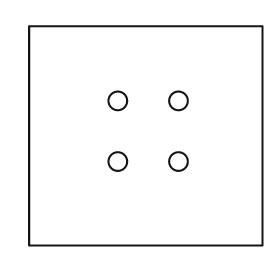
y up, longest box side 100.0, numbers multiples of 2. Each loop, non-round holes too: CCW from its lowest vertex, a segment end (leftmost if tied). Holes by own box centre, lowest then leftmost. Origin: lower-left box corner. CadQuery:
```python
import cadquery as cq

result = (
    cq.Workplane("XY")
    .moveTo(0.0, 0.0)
    .lineTo(100.0, 0.0)
    .lineTo(100.0, 94.0)
    .lineTo(0.0, 94.0)
    .close()
    .moveTo(38.0, 36.0)
    .circle(4.0)
    .moveTo(64.0, 36.0)
    .circle(4.0)
    .moveTo(38.0, 62.0)
    .circle(4.0)
    .moveTo(64.0, 62.0)
    .circle(4.0)
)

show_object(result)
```